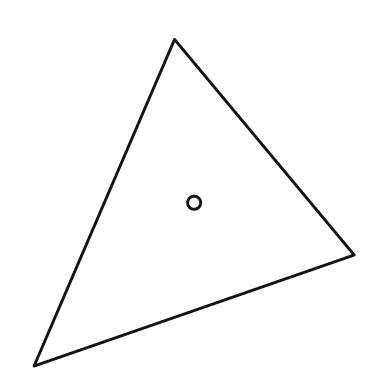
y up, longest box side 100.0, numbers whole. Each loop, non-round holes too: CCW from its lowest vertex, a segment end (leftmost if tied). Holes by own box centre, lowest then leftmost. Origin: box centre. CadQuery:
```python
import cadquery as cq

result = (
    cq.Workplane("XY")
    .moveTo(-49.0, -50.0)
    .lineTo(49.0, -16.0)
    .lineTo(-6.0, 50.0)
    .close()
    .moveTo(0.0, 0.0)
    .circle(2.0)
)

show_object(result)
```